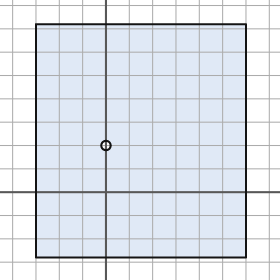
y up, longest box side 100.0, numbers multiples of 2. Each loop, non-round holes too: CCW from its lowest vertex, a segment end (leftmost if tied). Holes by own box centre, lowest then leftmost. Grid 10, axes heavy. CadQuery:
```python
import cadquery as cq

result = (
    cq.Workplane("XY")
    .moveTo(-30.0, -28.0)
    .lineTo(60.0, -28.0)
    .lineTo(60.0, 72.0)
    .lineTo(-30.0, 72.0)
    .close()
    .moveTo(0.0, 20.0)
    .circle(2.0)
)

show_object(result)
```